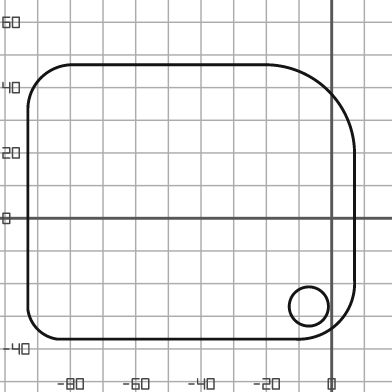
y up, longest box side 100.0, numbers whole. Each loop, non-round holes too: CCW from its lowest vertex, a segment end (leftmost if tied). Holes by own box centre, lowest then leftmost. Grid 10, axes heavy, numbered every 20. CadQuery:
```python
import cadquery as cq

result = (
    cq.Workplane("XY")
    .moveTo(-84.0, -37.0)
    .lineTo(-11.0, -37.0)
    .threePointArc((2.0, -32.0), (7.0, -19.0))
    .lineTo(7.0, 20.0)
    .threePointArc((-1.0, 39.0), (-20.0, 47.0))
    .lineTo(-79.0, 47.0)
    .threePointArc((-89.0, 43.0), (-93.0, 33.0))
    .lineTo(-93.0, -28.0)
    .threePointArc((-90.0, -34.0), (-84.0, -37.0))
    .close()
    .moveTo(-7.0, -27.0)
    .circle(6.0)
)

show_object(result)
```